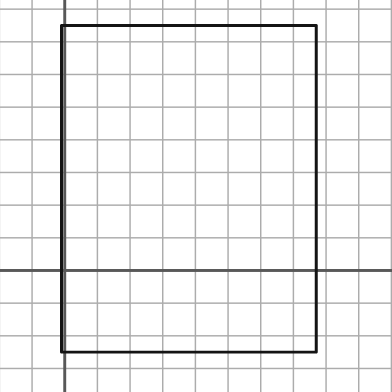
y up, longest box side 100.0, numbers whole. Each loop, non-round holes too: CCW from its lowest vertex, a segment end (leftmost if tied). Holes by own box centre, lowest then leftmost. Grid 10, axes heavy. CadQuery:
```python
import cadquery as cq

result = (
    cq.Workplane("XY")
    .moveTo(-1.0, -25.0)
    .lineTo(77.0, -25.0)
    .lineTo(77.0, 75.0)
    .lineTo(-1.0, 75.0)
    .close()
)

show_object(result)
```